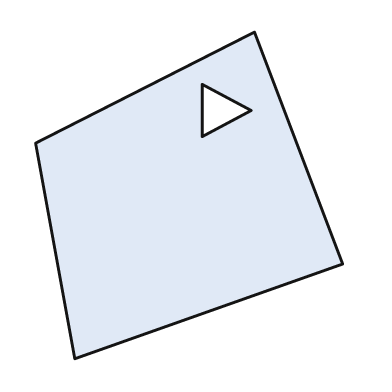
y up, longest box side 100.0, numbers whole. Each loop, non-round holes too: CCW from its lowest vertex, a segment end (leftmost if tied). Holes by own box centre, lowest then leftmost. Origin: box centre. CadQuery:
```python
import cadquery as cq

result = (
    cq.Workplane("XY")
    .moveTo(-35.0, -50.0)
    .lineTo(47.0, -21.0)
    .lineTo(20.0, 50.0)
    .lineTo(-47.0, 16.0)
    .close()
    .moveTo(4.0, 18.0)
    .lineTo(19.0, 26.0)
    .lineTo(4.0, 34.0)
    .close()
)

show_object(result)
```